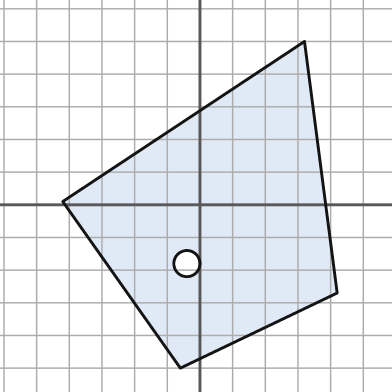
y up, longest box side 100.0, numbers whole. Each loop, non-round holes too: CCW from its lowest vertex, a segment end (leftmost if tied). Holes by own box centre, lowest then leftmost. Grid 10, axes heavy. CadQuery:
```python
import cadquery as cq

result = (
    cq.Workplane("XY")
    .moveTo(-6.0, -50.0)
    .lineTo(42.0, -27.0)
    .lineTo(32.0, 50.0)
    .lineTo(-42.0, 1.0)
    .close()
    .moveTo(-4.0, -18.0)
    .circle(4.0)
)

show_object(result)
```